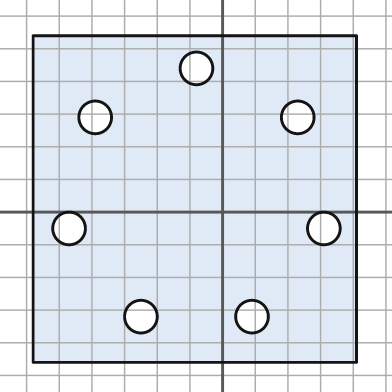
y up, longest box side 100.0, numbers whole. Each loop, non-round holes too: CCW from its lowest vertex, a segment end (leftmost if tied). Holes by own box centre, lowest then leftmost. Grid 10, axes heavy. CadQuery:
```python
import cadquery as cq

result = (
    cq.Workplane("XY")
    .moveTo(-58.0, -46.0)
    .lineTo(41.0, -46.0)
    .lineTo(41.0, 54.0)
    .lineTo(-58.0, 54.0)
    .close()
    .moveTo(-25.0, -32.0)
    .circle(5.0)
    .moveTo(9.0, -32.0)
    .circle(5.0)
    .moveTo(-47.0, -5.0)
    .circle(5.0)
    .moveTo(31.0, -5.0)
    .circle(5.0)
    .moveTo(-39.0, 29.0)
    .circle(5.0)
    .moveTo(23.0, 29.0)
    .circle(5.0)
    .moveTo(-8.0, 44.0)
    .circle(5.0)
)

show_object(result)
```